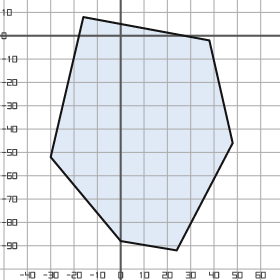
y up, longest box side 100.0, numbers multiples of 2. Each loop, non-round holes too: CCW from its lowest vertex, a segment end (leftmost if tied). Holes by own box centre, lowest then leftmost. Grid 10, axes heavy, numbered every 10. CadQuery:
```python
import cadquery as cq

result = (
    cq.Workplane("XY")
    .moveTo(24.0, -92.0)
    .lineTo(48.0, -46.0)
    .lineTo(38.0, -2.0)
    .lineTo(-16.0, 8.0)
    .lineTo(-30.0, -52.0)
    .lineTo(0.0, -88.0)
    .close()
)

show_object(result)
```